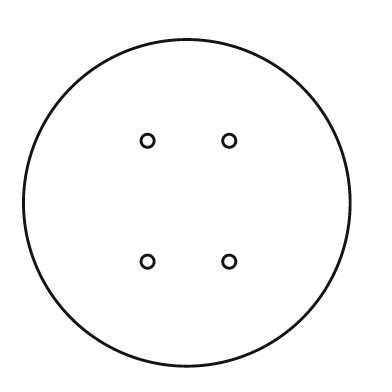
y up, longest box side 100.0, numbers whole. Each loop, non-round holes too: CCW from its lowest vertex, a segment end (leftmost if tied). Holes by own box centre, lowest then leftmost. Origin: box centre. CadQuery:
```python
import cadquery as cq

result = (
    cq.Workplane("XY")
    .moveTo(0.0, 0.0)
    .circle(50.0)
    .moveTo(-12.0, -18.0)
    .circle(2.0)
    .moveTo(13.0, -18.0)
    .circle(2.0)
    .moveTo(-12.0, 19.0)
    .circle(2.0)
    .moveTo(13.0, 19.0)
    .circle(2.0)
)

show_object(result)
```